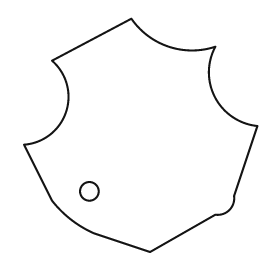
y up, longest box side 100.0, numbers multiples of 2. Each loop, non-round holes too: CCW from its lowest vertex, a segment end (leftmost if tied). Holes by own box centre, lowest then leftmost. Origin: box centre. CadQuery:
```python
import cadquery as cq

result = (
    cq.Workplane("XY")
    .moveTo(4.0, -50.0)
    .lineTo(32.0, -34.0)
    .threePointArc((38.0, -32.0), (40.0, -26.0))
    .lineTo(50.0, 4.0)
    .threePointArc((32.0, 16.0), (32.0, 38.0))
    .threePointArc((12.0, 38.0), (-4.0, 50.0))
    .lineTo(-38.0, 32.0)
    .threePointArc((-32.0, 10.0), (-50.0, -4.0))
    .lineTo(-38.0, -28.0)
    .threePointArc((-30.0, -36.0), (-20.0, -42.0))
    .close()
    .moveTo(-22.0, -24.0)
    .circle(4.0)
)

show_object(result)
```